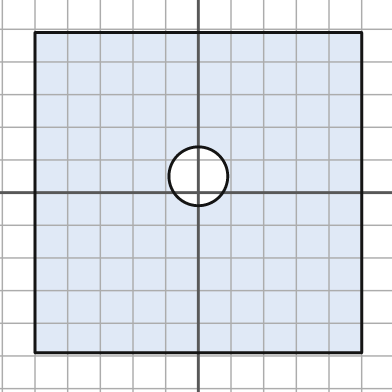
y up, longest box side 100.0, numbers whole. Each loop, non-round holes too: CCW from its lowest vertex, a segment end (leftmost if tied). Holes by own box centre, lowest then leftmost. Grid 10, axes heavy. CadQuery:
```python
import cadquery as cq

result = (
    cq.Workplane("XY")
    .moveTo(-50.0, -49.0)
    .lineTo(50.0, -49.0)
    .lineTo(50.0, 49.0)
    .lineTo(-50.0, 49.0)
    .close()
    .moveTo(0.0, 5.0)
    .circle(9.0)
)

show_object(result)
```